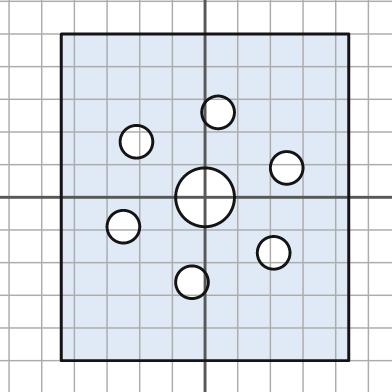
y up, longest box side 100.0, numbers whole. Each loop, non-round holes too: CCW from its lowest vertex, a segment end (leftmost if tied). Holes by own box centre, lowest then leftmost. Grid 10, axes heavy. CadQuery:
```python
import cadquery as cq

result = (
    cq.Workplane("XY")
    .moveTo(-44.0, -50.0)
    .lineTo(44.0, -50.0)
    .lineTo(44.0, 50.0)
    .lineTo(-44.0, 50.0)
    .close()
    .moveTo(-4.0, -26.0)
    .circle(5.0)
    .moveTo(21.0, -17.0)
    .circle(5.0)
    .moveTo(-25.0, -9.0)
    .circle(5.0)
    .moveTo(0.0, 0.0)
    .circle(9.0)
    .moveTo(25.0, 9.0)
    .circle(5.0)
    .moveTo(-21.0, 17.0)
    .circle(5.0)
    .moveTo(4.0, 26.0)
    .circle(5.0)
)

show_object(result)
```